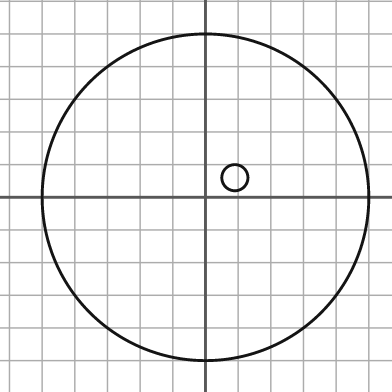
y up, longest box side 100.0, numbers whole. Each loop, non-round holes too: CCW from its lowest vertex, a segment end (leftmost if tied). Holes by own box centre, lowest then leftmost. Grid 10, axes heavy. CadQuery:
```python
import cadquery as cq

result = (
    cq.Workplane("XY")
    .moveTo(0.0, 0.0)
    .circle(50.0)
    .moveTo(9.0, 6.0)
    .circle(4.0)
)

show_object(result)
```